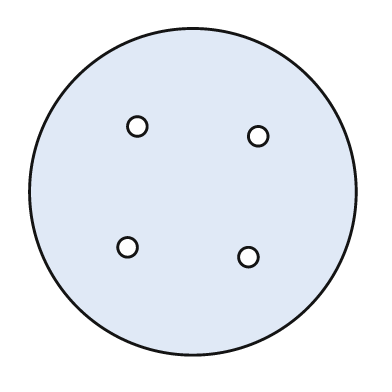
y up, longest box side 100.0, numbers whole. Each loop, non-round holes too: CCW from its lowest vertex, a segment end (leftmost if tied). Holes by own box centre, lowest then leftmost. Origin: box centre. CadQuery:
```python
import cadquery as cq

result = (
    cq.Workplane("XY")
    .moveTo(0.0, 0.0)
    .circle(50.0)
    .moveTo(17.0, -20.0)
    .circle(3.0)
    .moveTo(-20.0, -17.0)
    .circle(3.0)
    .moveTo(20.0, 17.0)
    .circle(3.0)
    .moveTo(-17.0, 20.0)
    .circle(3.0)
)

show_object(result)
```